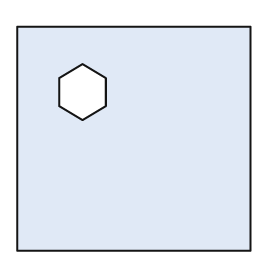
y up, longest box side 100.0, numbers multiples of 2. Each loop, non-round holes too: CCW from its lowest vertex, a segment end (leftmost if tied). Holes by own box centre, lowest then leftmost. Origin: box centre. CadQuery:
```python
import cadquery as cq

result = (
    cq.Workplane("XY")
    .moveTo(-50.0, -48.0)
    .lineTo(50.0, -48.0)
    .lineTo(50.0, 48.0)
    .lineTo(-50.0, 48.0)
    .close()
    .moveTo(-22.0, 8.0)
    .lineTo(-12.0, 14.0)
    .lineTo(-12.0, 26.0)
    .lineTo(-22.0, 32.0)
    .lineTo(-32.0, 26.0)
    .lineTo(-32.0, 14.0)
    .close()
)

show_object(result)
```